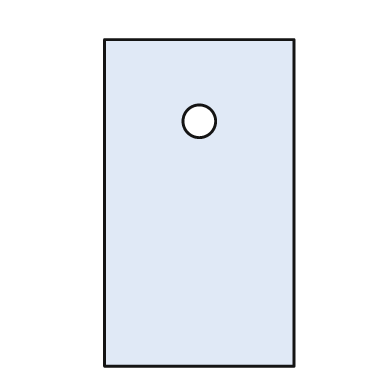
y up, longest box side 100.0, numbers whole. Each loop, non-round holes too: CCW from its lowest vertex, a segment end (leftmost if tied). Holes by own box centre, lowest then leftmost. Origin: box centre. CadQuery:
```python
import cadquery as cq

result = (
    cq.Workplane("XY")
    .moveTo(-29.0, -50.0)
    .lineTo(29.0, -50.0)
    .lineTo(29.0, 50.0)
    .lineTo(-29.0, 50.0)
    .close()
    .moveTo(0.0, 25.0)
    .circle(5.0)
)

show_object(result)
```